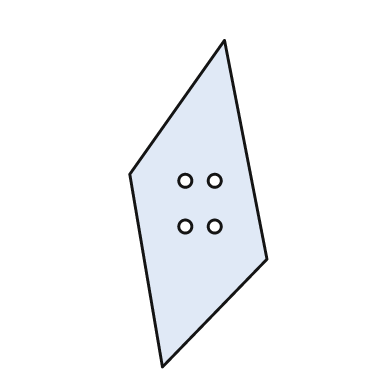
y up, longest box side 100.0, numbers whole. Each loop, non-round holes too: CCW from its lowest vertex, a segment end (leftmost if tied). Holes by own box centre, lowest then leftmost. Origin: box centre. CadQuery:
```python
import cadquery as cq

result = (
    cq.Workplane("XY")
    .moveTo(-11.0, -50.0)
    .lineTo(21.0, -17.0)
    .lineTo(8.0, 50.0)
    .lineTo(-21.0, 9.0)
    .close()
    .moveTo(-4.0, -7.0)
    .circle(2.0)
    .moveTo(5.0, -7.0)
    .circle(2.0)
    .moveTo(-4.0, 7.0)
    .circle(2.0)
    .moveTo(5.0, 7.0)
    .circle(2.0)
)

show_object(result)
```